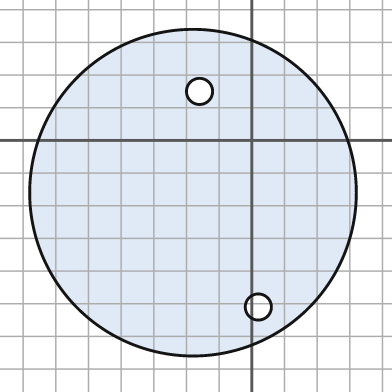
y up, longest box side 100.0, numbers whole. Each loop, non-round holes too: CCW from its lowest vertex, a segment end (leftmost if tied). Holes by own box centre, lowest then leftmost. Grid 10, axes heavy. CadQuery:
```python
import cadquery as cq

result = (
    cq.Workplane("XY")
    .moveTo(-18.0, -16.0)
    .circle(50.0)
    .moveTo(2.0, -51.0)
    .circle(4.0)
    .moveTo(-16.0, 15.0)
    .circle(4.0)
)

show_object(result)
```